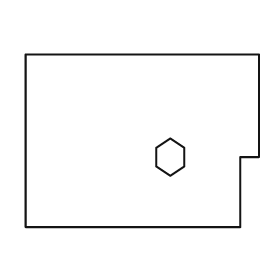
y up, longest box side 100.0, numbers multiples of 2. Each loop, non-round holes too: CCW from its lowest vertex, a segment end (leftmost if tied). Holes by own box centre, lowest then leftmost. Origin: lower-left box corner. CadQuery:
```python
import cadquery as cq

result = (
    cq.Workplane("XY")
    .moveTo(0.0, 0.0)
    .lineTo(92.0, 0.0)
    .lineTo(92.0, 30.0)
    .lineTo(100.0, 30.0)
    .lineTo(100.0, 74.0)
    .lineTo(0.0, 74.0)
    .close()
    .moveTo(62.0, 22.0)
    .lineTo(68.0, 26.0)
    .lineTo(68.0, 34.0)
    .lineTo(62.0, 38.0)
    .lineTo(56.0, 34.0)
    .lineTo(56.0, 26.0)
    .close()
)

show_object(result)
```